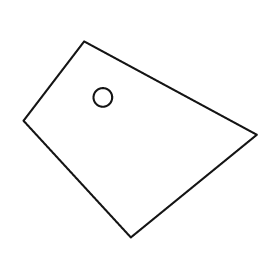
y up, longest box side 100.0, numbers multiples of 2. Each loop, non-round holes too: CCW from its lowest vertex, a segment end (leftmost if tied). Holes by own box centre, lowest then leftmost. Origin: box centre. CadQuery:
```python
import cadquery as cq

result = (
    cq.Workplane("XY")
    .moveTo(-4.0, -42.0)
    .lineTo(50.0, 2.0)
    .lineTo(-24.0, 42.0)
    .lineTo(-50.0, 8.0)
    .close()
    .moveTo(-16.0, 18.0)
    .circle(4.0)
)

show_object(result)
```